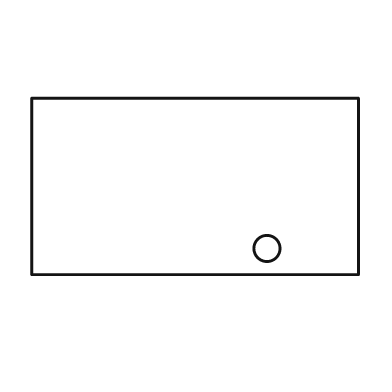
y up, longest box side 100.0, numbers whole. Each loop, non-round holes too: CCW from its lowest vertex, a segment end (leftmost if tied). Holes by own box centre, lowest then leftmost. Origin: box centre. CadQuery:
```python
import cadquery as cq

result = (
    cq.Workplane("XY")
    .moveTo(-50.0, -27.0)
    .lineTo(50.0, -27.0)
    .lineTo(50.0, 27.0)
    .lineTo(-50.0, 27.0)
    .close()
    .moveTo(22.0, -19.0)
    .circle(4.0)
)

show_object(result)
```